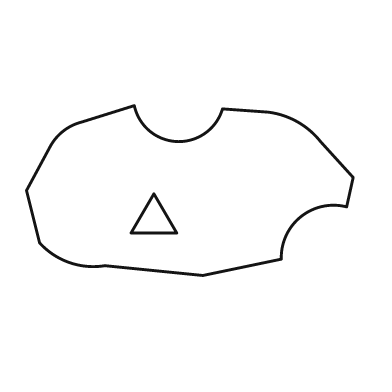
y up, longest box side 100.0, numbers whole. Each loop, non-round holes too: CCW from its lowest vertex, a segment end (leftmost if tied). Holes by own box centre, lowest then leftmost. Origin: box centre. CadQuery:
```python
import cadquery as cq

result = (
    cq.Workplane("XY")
    .moveTo(4.0, -26.0)
    .lineTo(28.0, -21.0)
    .threePointArc((34.0, -8.0), (48.0, -5.0))
    .lineTo(50.0, 4.0)
    .lineTo(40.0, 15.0)
    .threePointArc((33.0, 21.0), (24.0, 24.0))
    .lineTo(10.0, 25.0)
    .threePointArc((-4.0, 15.0), (-17.0, 26.0))
    .lineTo(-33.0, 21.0)
    .threePointArc((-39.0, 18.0), (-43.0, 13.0))
    .lineTo(-50.0, 0.0)
    .lineTo(-46.0, -16.0)
    .threePointArc((-37.0, -22.0), (-26.0, -23.0))
    .close()
    .moveTo(-18.0, -13.0)
    .lineTo(-4.0, -13.0)
    .lineTo(-11.0, -1.0)
    .close()
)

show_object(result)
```